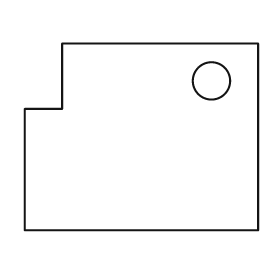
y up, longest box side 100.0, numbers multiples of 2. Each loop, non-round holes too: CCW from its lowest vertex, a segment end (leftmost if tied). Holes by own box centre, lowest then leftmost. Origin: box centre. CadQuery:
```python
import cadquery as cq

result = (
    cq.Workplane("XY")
    .moveTo(-50.0, -40.0)
    .lineTo(50.0, -40.0)
    .lineTo(50.0, 40.0)
    .lineTo(-34.0, 40.0)
    .lineTo(-34.0, 12.0)
    .lineTo(-50.0, 12.0)
    .close()
    .moveTo(30.0, 24.0)
    .circle(8.0)
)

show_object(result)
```